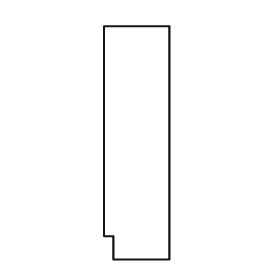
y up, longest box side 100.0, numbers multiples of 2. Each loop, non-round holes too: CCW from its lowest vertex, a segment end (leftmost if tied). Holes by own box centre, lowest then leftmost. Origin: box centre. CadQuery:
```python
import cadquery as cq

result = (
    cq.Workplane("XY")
    .moveTo(-10.0, -50.0)
    .lineTo(14.0, -50.0)
    .lineTo(14.0, 50.0)
    .lineTo(-14.0, 50.0)
    .lineTo(-14.0, -40.0)
    .lineTo(-10.0, -40.0)
    .close()
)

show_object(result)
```